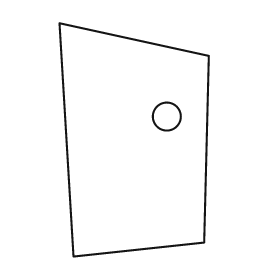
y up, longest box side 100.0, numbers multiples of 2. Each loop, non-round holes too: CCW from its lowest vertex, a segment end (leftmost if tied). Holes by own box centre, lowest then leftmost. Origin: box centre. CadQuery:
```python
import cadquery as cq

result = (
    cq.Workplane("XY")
    .moveTo(-26.0, -50.0)
    .lineTo(30.0, -44.0)
    .lineTo(32.0, 36.0)
    .lineTo(-32.0, 50.0)
    .close()
    .moveTo(14.0, 10.0)
    .circle(6.0)
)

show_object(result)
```